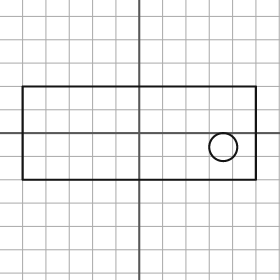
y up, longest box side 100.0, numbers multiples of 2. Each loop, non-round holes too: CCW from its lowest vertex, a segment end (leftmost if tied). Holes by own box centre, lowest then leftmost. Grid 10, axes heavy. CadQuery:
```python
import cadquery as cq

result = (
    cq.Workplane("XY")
    .moveTo(-50.0, -20.0)
    .lineTo(50.0, -20.0)
    .lineTo(50.0, 20.0)
    .lineTo(-50.0, 20.0)
    .close()
    .moveTo(36.0, -6.0)
    .circle(6.0)
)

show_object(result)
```